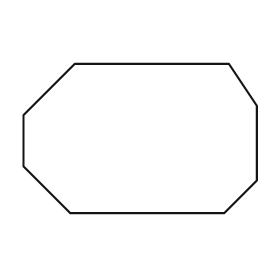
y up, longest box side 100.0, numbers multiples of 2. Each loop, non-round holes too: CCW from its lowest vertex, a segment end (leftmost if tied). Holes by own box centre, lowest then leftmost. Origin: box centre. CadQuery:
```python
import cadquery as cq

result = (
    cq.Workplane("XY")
    .moveTo(-30.0, -32.0)
    .lineTo(36.0, -32.0)
    .lineTo(50.0, -18.0)
    .lineTo(50.0, 14.0)
    .lineTo(38.0, 32.0)
    .lineTo(-28.0, 32.0)
    .lineTo(-50.0, 10.0)
    .lineTo(-50.0, -12.0)
    .close()
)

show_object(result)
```